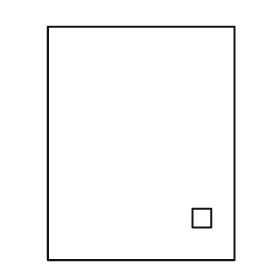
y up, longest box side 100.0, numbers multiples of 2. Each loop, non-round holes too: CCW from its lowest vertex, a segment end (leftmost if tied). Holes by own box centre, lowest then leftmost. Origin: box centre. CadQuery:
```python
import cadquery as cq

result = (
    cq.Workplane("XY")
    .moveTo(-40.0, -50.0)
    .lineTo(40.0, -50.0)
    .lineTo(40.0, 50.0)
    .lineTo(-40.0, 50.0)
    .close()
    .moveTo(22.0, -36.0)
    .lineTo(30.0, -36.0)
    .lineTo(30.0, -28.0)
    .lineTo(22.0, -28.0)
    .close()
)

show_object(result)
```